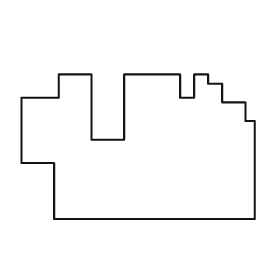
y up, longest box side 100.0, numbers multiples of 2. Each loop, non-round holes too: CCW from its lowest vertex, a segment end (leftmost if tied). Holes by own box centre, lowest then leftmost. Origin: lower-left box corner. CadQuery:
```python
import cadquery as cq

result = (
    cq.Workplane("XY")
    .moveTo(14.0, 0.0)
    .lineTo(100.0, 0.0)
    .lineTo(100.0, 42.0)
    .lineTo(96.0, 42.0)
    .lineTo(96.0, 50.0)
    .lineTo(86.0, 50.0)
    .lineTo(86.0, 58.0)
    .lineTo(80.0, 58.0)
    .lineTo(80.0, 62.0)
    .lineTo(74.0, 62.0)
    .lineTo(74.0, 52.0)
    .lineTo(68.0, 52.0)
    .lineTo(68.0, 62.0)
    .lineTo(44.0, 62.0)
    .lineTo(44.0, 34.0)
    .lineTo(30.0, 34.0)
    .lineTo(30.0, 62.0)
    .lineTo(16.0, 62.0)
    .lineTo(16.0, 52.0)
    .lineTo(0.0, 52.0)
    .lineTo(0.0, 24.0)
    .lineTo(14.0, 24.0)
    .close()
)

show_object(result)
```